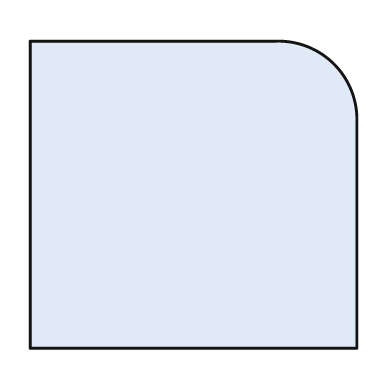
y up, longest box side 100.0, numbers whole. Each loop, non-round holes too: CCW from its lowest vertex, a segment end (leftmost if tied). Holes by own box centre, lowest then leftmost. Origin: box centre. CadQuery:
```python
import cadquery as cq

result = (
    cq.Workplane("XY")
    .moveTo(-50.0, -47.0)
    .lineTo(50.0, -47.0)
    .lineTo(50.0, 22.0)
    .threePointArc((43.0, 40.0), (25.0, 47.0))
    .lineTo(-50.0, 47.0)
    .close()
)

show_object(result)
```